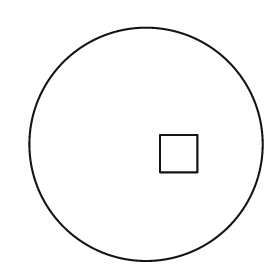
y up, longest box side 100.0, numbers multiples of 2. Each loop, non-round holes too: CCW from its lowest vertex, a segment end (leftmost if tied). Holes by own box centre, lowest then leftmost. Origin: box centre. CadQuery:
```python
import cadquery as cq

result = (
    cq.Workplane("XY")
    .moveTo(0.0, 0.0)
    .circle(50.0)
    .moveTo(6.0, -12.0)
    .lineTo(22.0, -12.0)
    .lineTo(22.0, 4.0)
    .lineTo(6.0, 4.0)
    .close()
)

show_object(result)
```